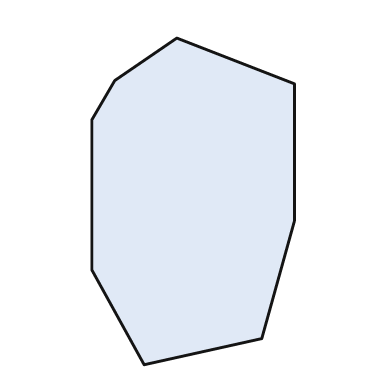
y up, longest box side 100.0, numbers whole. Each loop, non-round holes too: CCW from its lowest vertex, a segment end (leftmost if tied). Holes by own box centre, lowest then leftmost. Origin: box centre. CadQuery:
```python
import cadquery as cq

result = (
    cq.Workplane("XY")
    .moveTo(-15.0, -50.0)
    .lineTo(21.0, -42.0)
    .lineTo(31.0, -6.0)
    .lineTo(31.0, 36.0)
    .lineTo(-5.0, 50.0)
    .lineTo(-24.0, 37.0)
    .lineTo(-31.0, 25.0)
    .lineTo(-31.0, -21.0)
    .close()
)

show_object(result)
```